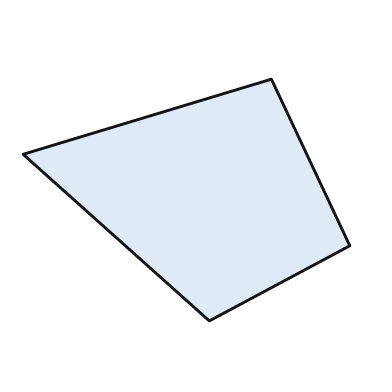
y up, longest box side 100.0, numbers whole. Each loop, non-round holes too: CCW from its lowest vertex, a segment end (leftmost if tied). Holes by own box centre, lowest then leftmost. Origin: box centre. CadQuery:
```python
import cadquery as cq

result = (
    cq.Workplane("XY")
    .moveTo(7.0, -37.0)
    .lineTo(50.0, -14.0)
    .lineTo(26.0, 37.0)
    .lineTo(-50.0, 14.0)
    .close()
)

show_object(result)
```